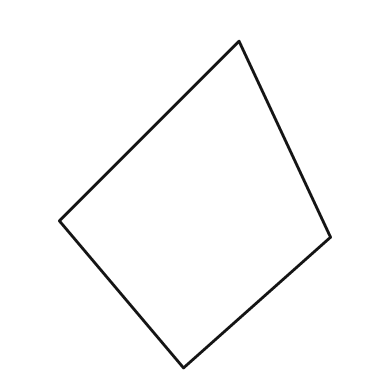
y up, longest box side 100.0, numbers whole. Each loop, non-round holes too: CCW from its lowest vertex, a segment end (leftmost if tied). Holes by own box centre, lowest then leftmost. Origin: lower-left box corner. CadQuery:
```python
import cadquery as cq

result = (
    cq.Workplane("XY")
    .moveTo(38.0, 0.0)
    .lineTo(83.0, 40.0)
    .lineTo(55.0, 100.0)
    .lineTo(0.0, 45.0)
    .close()
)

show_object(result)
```